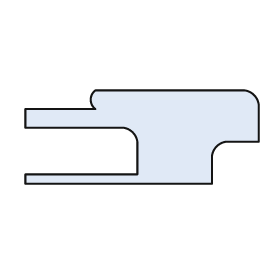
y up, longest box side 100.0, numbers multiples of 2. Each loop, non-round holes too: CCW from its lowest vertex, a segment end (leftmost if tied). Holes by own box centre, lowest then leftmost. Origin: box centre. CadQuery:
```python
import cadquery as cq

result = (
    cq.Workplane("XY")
    .moveTo(-50.0, -20.0)
    .lineTo(30.0, -20.0)
    .lineTo(30.0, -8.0)
    .threePointArc((32.0, -4.0), (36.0, -2.0))
    .lineTo(50.0, -2.0)
    .lineTo(50.0, 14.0)
    .threePointArc((48.0, 18.0), (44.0, 20.0))
    .lineTo(-20.0, 20.0)
    .threePointArc((-22.0, 16.0), (-20.0, 12.0))
    .lineTo(-50.0, 12.0)
    .lineTo(-50.0, 4.0)
    .lineTo(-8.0, 4.0)
    .threePointArc((-4.0, 2.0), (-2.0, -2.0))
    .lineTo(-2.0, -16.0)
    .lineTo(-50.0, -16.0)
    .close()
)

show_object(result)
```